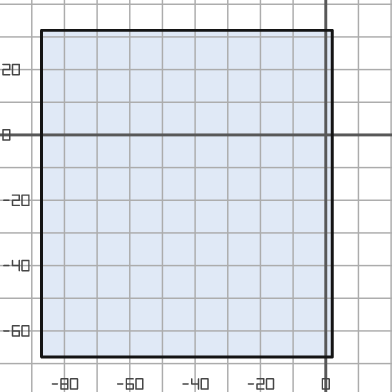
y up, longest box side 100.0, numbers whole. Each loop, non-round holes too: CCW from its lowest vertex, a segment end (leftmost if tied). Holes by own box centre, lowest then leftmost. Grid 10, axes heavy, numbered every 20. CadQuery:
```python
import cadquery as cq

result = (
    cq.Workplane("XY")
    .moveTo(-87.0, -68.0)
    .lineTo(2.0, -68.0)
    .lineTo(2.0, 32.0)
    .lineTo(-87.0, 32.0)
    .close()
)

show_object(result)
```